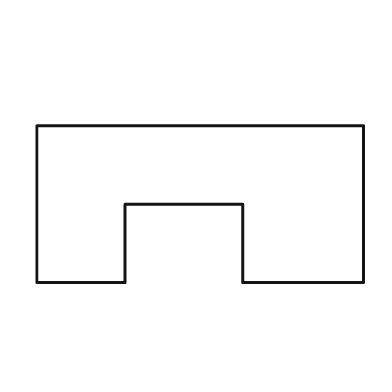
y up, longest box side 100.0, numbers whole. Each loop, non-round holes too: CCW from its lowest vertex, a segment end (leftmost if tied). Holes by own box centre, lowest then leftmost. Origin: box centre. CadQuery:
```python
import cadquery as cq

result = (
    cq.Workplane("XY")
    .moveTo(-50.0, -24.0)
    .lineTo(-23.0, -24.0)
    .lineTo(-23.0, 0.0)
    .lineTo(13.0, 0.0)
    .lineTo(13.0, -24.0)
    .lineTo(50.0, -24.0)
    .lineTo(50.0, 24.0)
    .lineTo(-50.0, 24.0)
    .close()
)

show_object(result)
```